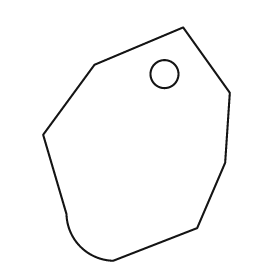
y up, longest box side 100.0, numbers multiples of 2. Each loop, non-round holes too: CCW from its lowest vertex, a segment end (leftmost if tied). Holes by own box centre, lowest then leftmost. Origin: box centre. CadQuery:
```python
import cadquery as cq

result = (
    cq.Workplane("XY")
    .moveTo(-10.0, -50.0)
    .lineTo(26.0, -36.0)
    .lineTo(38.0, -8.0)
    .lineTo(40.0, 22.0)
    .lineTo(20.0, 50.0)
    .lineTo(-18.0, 34.0)
    .lineTo(-40.0, 4.0)
    .lineTo(-30.0, -30.0)
    .threePointArc((-24.0, -44.0), (-10.0, -50.0))
    .close()
    .moveTo(12.0, 30.0)
    .circle(6.0)
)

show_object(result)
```